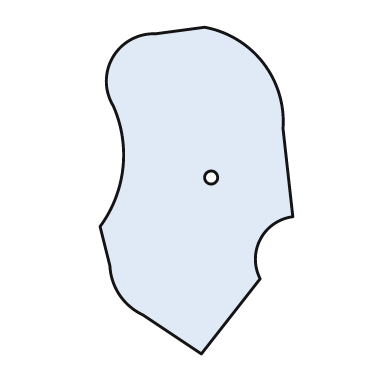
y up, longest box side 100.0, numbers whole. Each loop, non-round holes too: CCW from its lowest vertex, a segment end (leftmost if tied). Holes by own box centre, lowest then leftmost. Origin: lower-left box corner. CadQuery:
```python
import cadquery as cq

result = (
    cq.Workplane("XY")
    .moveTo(31.0, 0.0)
    .lineTo(49.0, 23.0)
    .threePointArc((49.0, 35.0), (59.0, 42.0))
    .lineTo(56.0, 69.0)
    .threePointArc((50.0, 89.0), (32.0, 100.0))
    .lineTo(17.0, 98.0)
    .threePointArc((4.0, 91.0), (4.0, 76.0))
    .threePointArc((7.0, 57.0), (0.0, 39.0))
    .lineTo(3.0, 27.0)
    .threePointArc((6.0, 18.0), (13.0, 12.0))
    .close()
    .moveTo(34.0, 54.0)
    .circle(2.0)
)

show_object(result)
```